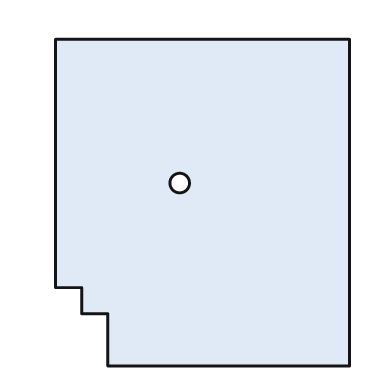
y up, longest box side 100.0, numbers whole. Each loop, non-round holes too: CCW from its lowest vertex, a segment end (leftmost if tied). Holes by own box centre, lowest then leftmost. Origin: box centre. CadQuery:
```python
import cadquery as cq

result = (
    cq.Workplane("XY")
    .moveTo(-29.0, -50.0)
    .lineTo(45.0, -50.0)
    .lineTo(45.0, 50.0)
    .lineTo(-45.0, 50.0)
    .lineTo(-45.0, -26.0)
    .lineTo(-37.0, -26.0)
    .lineTo(-37.0, -34.0)
    .lineTo(-29.0, -34.0)
    .close()
    .moveTo(-7.0, 6.0)
    .circle(3.0)
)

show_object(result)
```